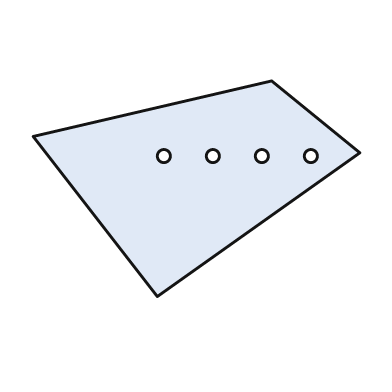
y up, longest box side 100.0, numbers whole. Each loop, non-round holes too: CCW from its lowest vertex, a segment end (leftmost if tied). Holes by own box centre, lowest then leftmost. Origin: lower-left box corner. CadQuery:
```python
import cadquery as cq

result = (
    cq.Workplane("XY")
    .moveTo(38.0, 0.0)
    .lineTo(100.0, 44.0)
    .lineTo(73.0, 66.0)
    .lineTo(0.0, 49.0)
    .close()
    .moveTo(40.0, 43.0)
    .circle(2.0)
    .moveTo(55.0, 43.0)
    .circle(2.0)
    .moveTo(70.0, 43.0)
    .circle(2.0)
    .moveTo(85.0, 43.0)
    .circle(2.0)
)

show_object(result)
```